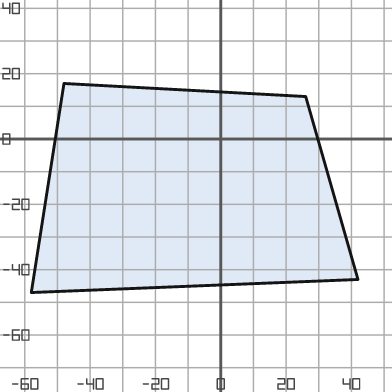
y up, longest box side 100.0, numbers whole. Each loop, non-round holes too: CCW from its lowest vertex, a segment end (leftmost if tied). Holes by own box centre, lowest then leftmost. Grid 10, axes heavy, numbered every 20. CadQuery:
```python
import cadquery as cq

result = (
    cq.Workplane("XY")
    .moveTo(-58.0, -47.0)
    .lineTo(42.0, -43.0)
    .lineTo(26.0, 13.0)
    .lineTo(-48.0, 17.0)
    .close()
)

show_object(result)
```